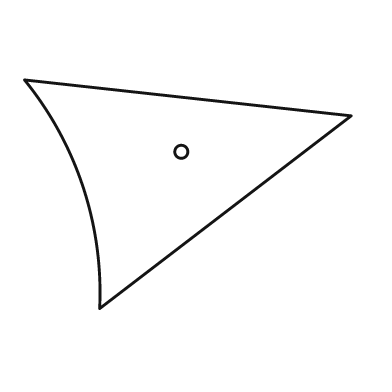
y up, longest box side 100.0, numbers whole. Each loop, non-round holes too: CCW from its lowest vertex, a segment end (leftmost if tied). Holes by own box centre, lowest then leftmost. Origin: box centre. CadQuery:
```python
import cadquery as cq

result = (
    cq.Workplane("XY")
    .moveTo(-27.0, -35.0)
    .lineTo(50.0, 24.0)
    .lineTo(-50.0, 35.0)
    .threePointArc((-32.0, 2.0), (-27.0, -35.0))
    .close()
    .moveTo(-2.0, 13.0)
    .circle(2.0)
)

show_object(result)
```